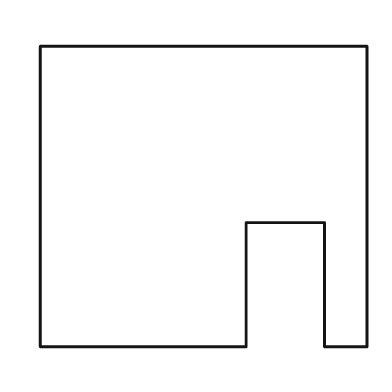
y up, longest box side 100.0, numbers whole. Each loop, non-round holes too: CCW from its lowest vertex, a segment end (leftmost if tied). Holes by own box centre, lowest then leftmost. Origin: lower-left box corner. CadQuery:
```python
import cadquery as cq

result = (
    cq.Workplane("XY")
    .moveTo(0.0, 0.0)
    .lineTo(63.0, 0.0)
    .lineTo(63.0, 38.0)
    .lineTo(87.0, 38.0)
    .lineTo(87.0, 0.0)
    .lineTo(100.0, 0.0)
    .lineTo(100.0, 92.0)
    .lineTo(0.0, 92.0)
    .close()
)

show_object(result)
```